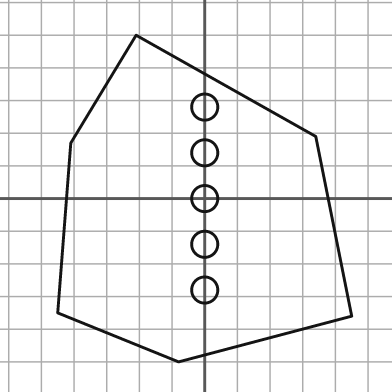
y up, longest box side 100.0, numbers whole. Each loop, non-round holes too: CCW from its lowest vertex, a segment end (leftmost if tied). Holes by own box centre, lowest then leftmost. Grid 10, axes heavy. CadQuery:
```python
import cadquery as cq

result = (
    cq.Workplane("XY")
    .moveTo(-8.0, -50.0)
    .lineTo(45.0, -36.0)
    .lineTo(34.0, 19.0)
    .lineTo(-21.0, 50.0)
    .lineTo(-41.0, 17.0)
    .lineTo(-45.0, -35.0)
    .close()
    .moveTo(0.0, -28.0)
    .circle(4.0)
    .moveTo(0.0, -14.0)
    .circle(4.0)
    .moveTo(0.0, 0.0)
    .circle(4.0)
    .moveTo(0.0, 14.0)
    .circle(4.0)
    .moveTo(0.0, 28.0)
    .circle(4.0)
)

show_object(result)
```